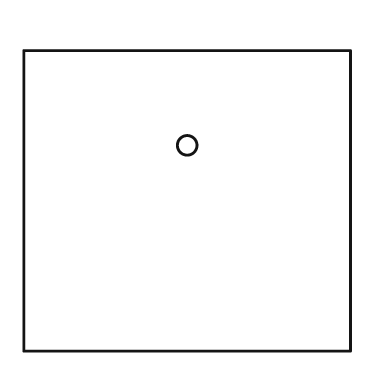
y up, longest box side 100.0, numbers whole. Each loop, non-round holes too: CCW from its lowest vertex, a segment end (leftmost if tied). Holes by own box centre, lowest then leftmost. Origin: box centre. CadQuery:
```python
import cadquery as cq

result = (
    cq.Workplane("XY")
    .moveTo(-50.0, -46.0)
    .lineTo(50.0, -46.0)
    .lineTo(50.0, 46.0)
    .lineTo(-50.0, 46.0)
    .close()
    .moveTo(0.0, 17.0)
    .circle(3.0)
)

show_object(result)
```